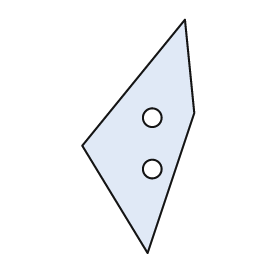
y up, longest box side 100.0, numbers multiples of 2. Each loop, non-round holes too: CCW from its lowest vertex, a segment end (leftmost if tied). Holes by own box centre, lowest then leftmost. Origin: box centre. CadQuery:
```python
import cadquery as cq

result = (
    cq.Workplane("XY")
    .moveTo(4.0, -50.0)
    .lineTo(24.0, 10.0)
    .lineTo(20.0, 50.0)
    .lineTo(-24.0, -4.0)
    .close()
    .moveTo(6.0, -14.0)
    .circle(4.0)
    .moveTo(6.0, 8.0)
    .circle(4.0)
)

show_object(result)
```